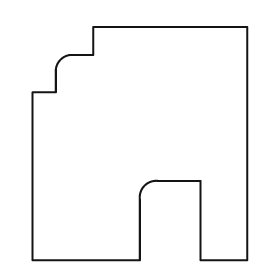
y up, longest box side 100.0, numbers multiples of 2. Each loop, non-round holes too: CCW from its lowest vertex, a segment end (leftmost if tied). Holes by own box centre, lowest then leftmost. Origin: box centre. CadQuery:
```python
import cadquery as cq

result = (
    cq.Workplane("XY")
    .moveTo(-46.0, -50.0)
    .lineTo(0.0, -50.0)
    .lineTo(0.0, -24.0)
    .threePointArc((2.0, -18.0), (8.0, -16.0))
    .lineTo(26.0, -16.0)
    .lineTo(26.0, -50.0)
    .lineTo(46.0, -50.0)
    .lineTo(46.0, 50.0)
    .lineTo(-20.0, 50.0)
    .lineTo(-20.0, 38.0)
    .lineTo(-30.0, 38.0)
    .threePointArc((-34.0, 36.0), (-36.0, 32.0))
    .lineTo(-36.0, 22.0)
    .lineTo(-46.0, 22.0)
    .close()
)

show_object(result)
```